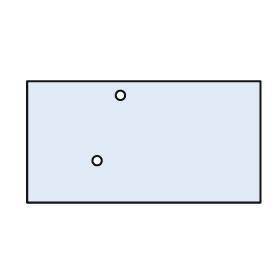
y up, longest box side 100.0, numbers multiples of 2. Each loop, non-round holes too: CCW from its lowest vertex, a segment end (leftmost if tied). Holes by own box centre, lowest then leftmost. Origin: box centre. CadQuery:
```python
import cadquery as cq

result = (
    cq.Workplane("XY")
    .moveTo(-50.0, -26.0)
    .lineTo(50.0, -26.0)
    .lineTo(50.0, 26.0)
    .lineTo(-50.0, 26.0)
    .close()
    .moveTo(-20.0, -8.0)
    .circle(2.0)
    .moveTo(-10.0, 20.0)
    .circle(2.0)
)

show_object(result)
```